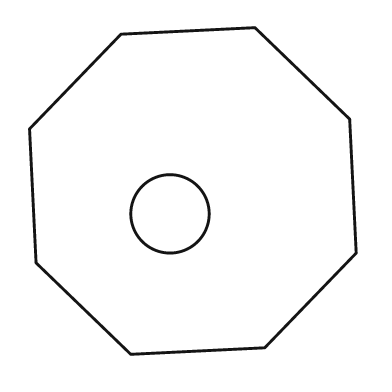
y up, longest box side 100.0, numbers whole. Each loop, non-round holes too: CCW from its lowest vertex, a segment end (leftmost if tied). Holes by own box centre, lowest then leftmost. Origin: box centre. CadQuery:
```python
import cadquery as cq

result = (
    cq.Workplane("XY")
    .moveTo(-19.0, -50.0)
    .lineTo(22.0, -48.0)
    .lineTo(50.0, -19.0)
    .lineTo(48.0, 22.0)
    .lineTo(19.0, 50.0)
    .lineTo(-22.0, 48.0)
    .lineTo(-50.0, 19.0)
    .lineTo(-48.0, -22.0)
    .close()
    .moveTo(-7.0, -7.0)
    .circle(12.0)
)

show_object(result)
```